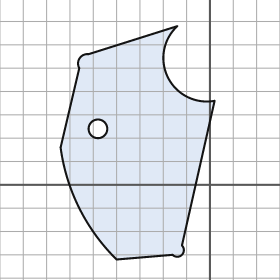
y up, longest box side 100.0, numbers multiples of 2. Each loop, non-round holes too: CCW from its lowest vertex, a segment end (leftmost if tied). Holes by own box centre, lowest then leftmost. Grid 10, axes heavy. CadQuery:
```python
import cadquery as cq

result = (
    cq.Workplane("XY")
    .moveTo(-40.0, -32.0)
    .lineTo(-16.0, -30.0)
    .threePointArc((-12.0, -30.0), (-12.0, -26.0))
    .lineTo(2.0, 36.0)
    .threePointArc((-18.0, 46.0), (-14.0, 68.0))
    .lineTo(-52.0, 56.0)
    .threePointArc((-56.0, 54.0), (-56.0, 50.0))
    .lineTo(-64.0, 16.0)
    .threePointArc((-56.0, -10.0), (-40.0, -32.0))
    .close()
    .moveTo(-48.0, 24.0)
    .circle(4.0)
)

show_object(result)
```